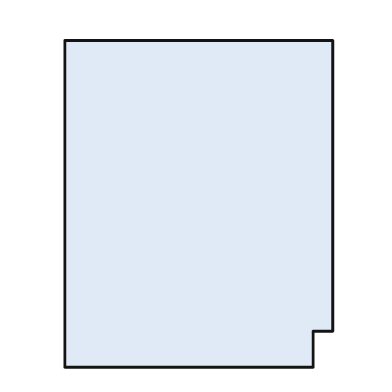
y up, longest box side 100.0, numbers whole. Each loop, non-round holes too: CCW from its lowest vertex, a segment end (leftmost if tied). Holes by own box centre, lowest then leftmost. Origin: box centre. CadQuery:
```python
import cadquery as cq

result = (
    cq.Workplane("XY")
    .moveTo(-41.0, -50.0)
    .lineTo(35.0, -50.0)
    .lineTo(35.0, -39.0)
    .lineTo(41.0, -39.0)
    .lineTo(41.0, 50.0)
    .lineTo(-41.0, 50.0)
    .close()
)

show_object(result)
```